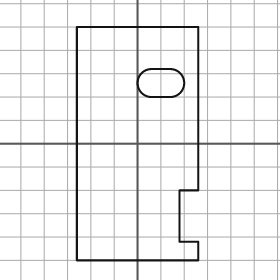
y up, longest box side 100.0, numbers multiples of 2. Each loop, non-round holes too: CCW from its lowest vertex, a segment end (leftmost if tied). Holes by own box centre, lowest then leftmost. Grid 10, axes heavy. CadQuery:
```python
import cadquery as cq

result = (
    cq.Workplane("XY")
    .moveTo(-26.0, -50.0)
    .lineTo(26.0, -50.0)
    .lineTo(26.0, -42.0)
    .lineTo(18.0, -42.0)
    .lineTo(18.0, -20.0)
    .lineTo(26.0, -20.0)
    .lineTo(26.0, 50.0)
    .lineTo(-26.0, 50.0)
    .close()
    .moveTo(6.0, 20.0)
    .lineTo(14.0, 20.0)
    .threePointArc((20.0, 26.0), (14.0, 32.0))
    .lineTo(6.0, 32.0)
    .threePointArc((0.0, 26.0), (6.0, 20.0))
    .close()
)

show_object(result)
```